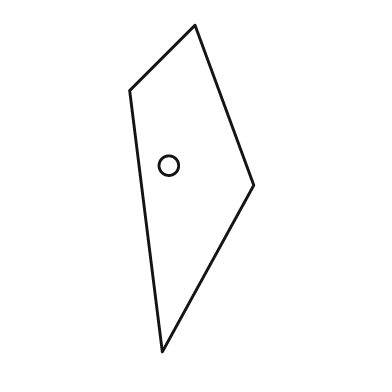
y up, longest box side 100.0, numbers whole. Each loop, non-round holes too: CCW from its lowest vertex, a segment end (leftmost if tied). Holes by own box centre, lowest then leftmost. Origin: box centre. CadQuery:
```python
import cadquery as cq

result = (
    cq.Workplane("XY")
    .moveTo(-9.0, -50.0)
    .lineTo(19.0, 1.0)
    .lineTo(1.0, 50.0)
    .lineTo(-19.0, 30.0)
    .close()
    .moveTo(-7.0, 7.0)
    .circle(3.0)
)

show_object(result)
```